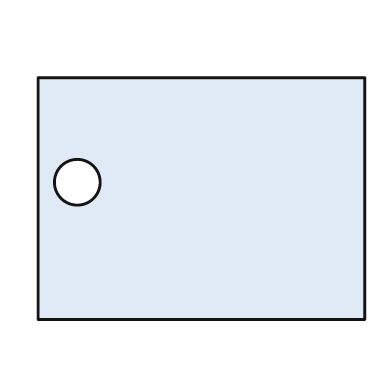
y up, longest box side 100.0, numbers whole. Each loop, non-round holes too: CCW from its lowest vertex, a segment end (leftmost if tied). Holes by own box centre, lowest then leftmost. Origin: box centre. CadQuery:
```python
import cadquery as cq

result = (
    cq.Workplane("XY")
    .moveTo(-50.0, -37.0)
    .lineTo(50.0, -37.0)
    .lineTo(50.0, 37.0)
    .lineTo(-50.0, 37.0)
    .close()
    .moveTo(-38.0, 5.0)
    .circle(7.0)
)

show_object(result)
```